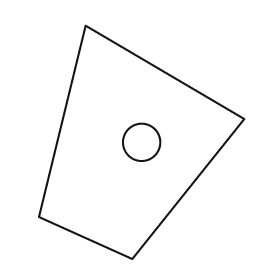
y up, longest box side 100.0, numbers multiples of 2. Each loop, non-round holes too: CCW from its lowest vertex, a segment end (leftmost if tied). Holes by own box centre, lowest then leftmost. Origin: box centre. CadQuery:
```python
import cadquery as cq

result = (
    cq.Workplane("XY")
    .moveTo(-4.0, -50.0)
    .lineTo(44.0, 10.0)
    .lineTo(-24.0, 50.0)
    .lineTo(-44.0, -32.0)
    .close()
    .moveTo(0.0, 0.0)
    .circle(8.0)
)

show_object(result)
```